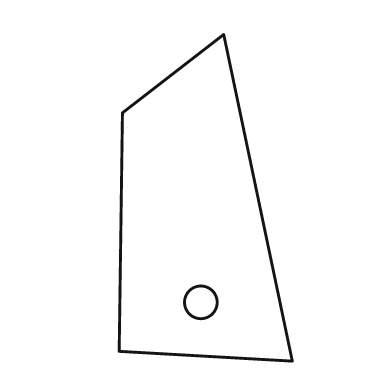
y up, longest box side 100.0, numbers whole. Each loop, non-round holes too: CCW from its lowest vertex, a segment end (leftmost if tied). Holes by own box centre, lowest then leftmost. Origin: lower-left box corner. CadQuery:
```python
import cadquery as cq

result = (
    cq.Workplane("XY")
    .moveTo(53.0, 0.0)
    .lineTo(32.0, 100.0)
    .lineTo(1.0, 76.0)
    .lineTo(0.0, 3.0)
    .close()
    .moveTo(25.0, 18.0)
    .circle(5.0)
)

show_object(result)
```